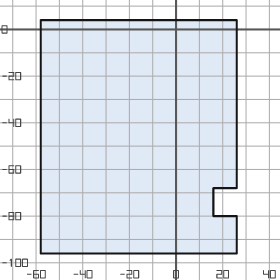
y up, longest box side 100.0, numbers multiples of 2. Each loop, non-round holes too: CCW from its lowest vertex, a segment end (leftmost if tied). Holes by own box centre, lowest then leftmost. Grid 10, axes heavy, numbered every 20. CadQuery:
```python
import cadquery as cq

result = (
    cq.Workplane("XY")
    .moveTo(-58.0, -96.0)
    .lineTo(26.0, -96.0)
    .lineTo(26.0, -80.0)
    .lineTo(16.0, -80.0)
    .lineTo(16.0, -68.0)
    .lineTo(26.0, -68.0)
    .lineTo(26.0, 4.0)
    .lineTo(-58.0, 4.0)
    .close()
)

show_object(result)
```